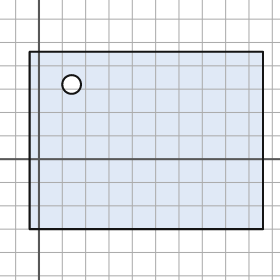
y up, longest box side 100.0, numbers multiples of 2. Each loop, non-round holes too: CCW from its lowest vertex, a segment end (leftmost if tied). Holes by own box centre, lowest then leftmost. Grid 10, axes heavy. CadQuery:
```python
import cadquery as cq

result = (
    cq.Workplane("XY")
    .moveTo(-4.0, -30.0)
    .lineTo(96.0, -30.0)
    .lineTo(96.0, 46.0)
    .lineTo(-4.0, 46.0)
    .close()
    .moveTo(14.0, 32.0)
    .circle(4.0)
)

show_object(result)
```